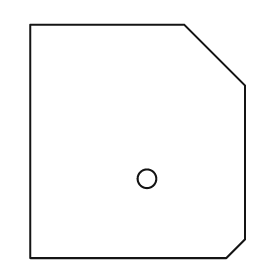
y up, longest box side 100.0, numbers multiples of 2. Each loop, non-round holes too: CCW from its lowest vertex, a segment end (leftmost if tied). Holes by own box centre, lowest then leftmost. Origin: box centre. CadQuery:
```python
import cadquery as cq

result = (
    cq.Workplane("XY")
    .moveTo(-46.0, -50.0)
    .lineTo(38.0, -50.0)
    .lineTo(46.0, -42.0)
    .lineTo(46.0, 24.0)
    .lineTo(20.0, 50.0)
    .lineTo(-46.0, 50.0)
    .close()
    .moveTo(4.0, -16.0)
    .circle(4.0)
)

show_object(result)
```